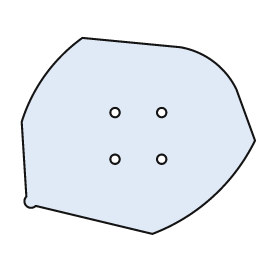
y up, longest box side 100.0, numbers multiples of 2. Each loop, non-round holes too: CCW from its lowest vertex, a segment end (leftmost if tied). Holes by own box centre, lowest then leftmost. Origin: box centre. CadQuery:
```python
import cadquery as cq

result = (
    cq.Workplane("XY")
    .moveTo(6.0, -42.0)
    .threePointArc((32.0, -26.0), (50.0, -2.0))
    .lineTo(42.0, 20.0)
    .threePointArc((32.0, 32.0), (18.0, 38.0))
    .lineTo(-24.0, 42.0)
    .threePointArc((-40.0, 26.0), (-50.0, 6.0))
    .lineTo(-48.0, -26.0)
    .threePointArc((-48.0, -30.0), (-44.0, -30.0))
    .close()
    .moveTo(-10.0, -10.0)
    .circle(2.0)
    .moveTo(10.0, -10.0)
    .circle(2.0)
    .moveTo(-10.0, 10.0)
    .circle(2.0)
    .moveTo(10.0, 10.0)
    .circle(2.0)
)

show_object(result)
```